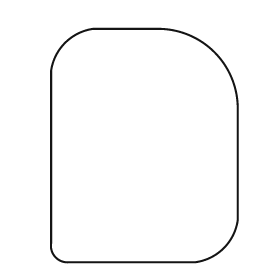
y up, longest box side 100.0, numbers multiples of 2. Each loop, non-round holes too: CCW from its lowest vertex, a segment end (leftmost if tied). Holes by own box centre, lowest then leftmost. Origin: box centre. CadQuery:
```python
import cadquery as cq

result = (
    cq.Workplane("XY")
    .moveTo(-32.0, -50.0)
    .lineTo(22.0, -50.0)
    .threePointArc((34.0, -44.0), (40.0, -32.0))
    .lineTo(40.0, 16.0)
    .threePointArc((30.0, 40.0), (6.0, 50.0))
    .lineTo(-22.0, 50.0)
    .threePointArc((-34.0, 44.0), (-40.0, 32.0))
    .lineTo(-40.0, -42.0)
    .threePointArc((-38.0, -48.0), (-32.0, -50.0))
    .close()
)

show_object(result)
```